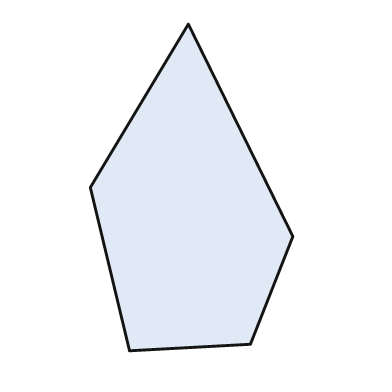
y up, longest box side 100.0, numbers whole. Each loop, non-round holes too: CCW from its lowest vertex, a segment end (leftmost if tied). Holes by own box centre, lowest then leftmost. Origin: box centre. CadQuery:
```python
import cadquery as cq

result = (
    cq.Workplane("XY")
    .moveTo(-19.0, -50.0)
    .lineTo(18.0, -48.0)
    .lineTo(31.0, -15.0)
    .lineTo(-1.0, 50.0)
    .lineTo(-31.0, 0.0)
    .close()
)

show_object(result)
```